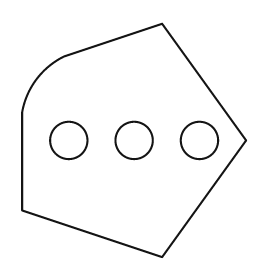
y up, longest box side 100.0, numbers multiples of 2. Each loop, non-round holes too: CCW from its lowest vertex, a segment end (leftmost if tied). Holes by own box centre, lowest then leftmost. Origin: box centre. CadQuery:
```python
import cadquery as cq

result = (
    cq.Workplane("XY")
    .moveTo(12.0, -50.0)
    .lineTo(48.0, 0.0)
    .lineTo(12.0, 50.0)
    .lineTo(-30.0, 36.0)
    .threePointArc((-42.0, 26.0), (-48.0, 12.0))
    .lineTo(-48.0, -30.0)
    .close()
    .moveTo(-28.0, 0.0)
    .circle(8.0)
    .moveTo(0.0, 0.0)
    .circle(8.0)
    .moveTo(28.0, 0.0)
    .circle(8.0)
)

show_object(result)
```